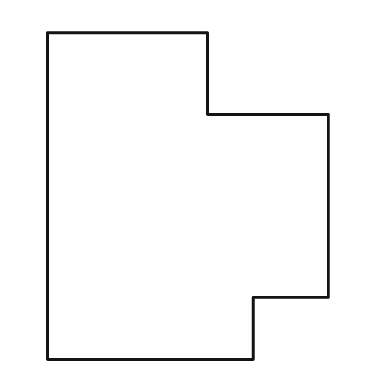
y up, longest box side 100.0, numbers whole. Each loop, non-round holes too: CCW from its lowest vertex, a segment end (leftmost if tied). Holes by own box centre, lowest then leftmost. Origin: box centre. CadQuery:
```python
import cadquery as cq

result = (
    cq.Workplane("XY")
    .moveTo(-43.0, -50.0)
    .lineTo(20.0, -50.0)
    .lineTo(20.0, -31.0)
    .lineTo(43.0, -31.0)
    .lineTo(43.0, 25.0)
    .lineTo(6.0, 25.0)
    .lineTo(6.0, 50.0)
    .lineTo(-43.0, 50.0)
    .close()
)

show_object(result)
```